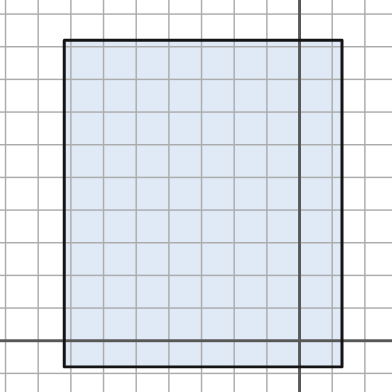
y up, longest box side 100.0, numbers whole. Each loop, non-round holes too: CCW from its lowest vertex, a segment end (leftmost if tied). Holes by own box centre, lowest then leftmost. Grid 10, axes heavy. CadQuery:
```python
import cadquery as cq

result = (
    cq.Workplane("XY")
    .moveTo(-72.0, -8.0)
    .lineTo(13.0, -8.0)
    .lineTo(13.0, 92.0)
    .lineTo(-72.0, 92.0)
    .close()
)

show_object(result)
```